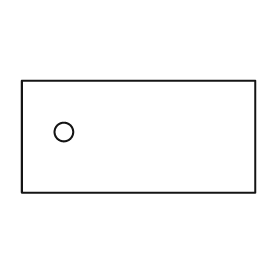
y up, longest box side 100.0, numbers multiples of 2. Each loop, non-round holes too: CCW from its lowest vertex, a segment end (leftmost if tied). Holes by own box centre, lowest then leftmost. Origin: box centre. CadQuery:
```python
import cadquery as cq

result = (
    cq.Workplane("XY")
    .moveTo(-50.0, -24.0)
    .lineTo(50.0, -24.0)
    .lineTo(50.0, 24.0)
    .lineTo(-50.0, 24.0)
    .close()
    .moveTo(-32.0, 2.0)
    .circle(4.0)
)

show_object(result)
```